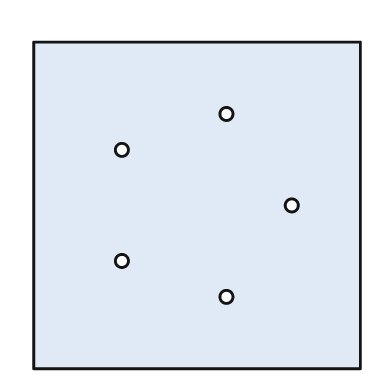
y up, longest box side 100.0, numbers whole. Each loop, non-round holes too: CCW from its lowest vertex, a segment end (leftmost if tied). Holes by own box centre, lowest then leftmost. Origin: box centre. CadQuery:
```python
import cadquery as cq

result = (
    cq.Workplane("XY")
    .moveTo(-50.0, -50.0)
    .lineTo(50.0, -50.0)
    .lineTo(50.0, 50.0)
    .lineTo(-50.0, 50.0)
    .close()
    .moveTo(9.0, -28.0)
    .circle(2.0)
    .moveTo(-23.0, -17.0)
    .circle(2.0)
    .moveTo(29.0, 0.0)
    .circle(2.0)
    .moveTo(-23.0, 17.0)
    .circle(2.0)
    .moveTo(9.0, 28.0)
    .circle(2.0)
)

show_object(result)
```